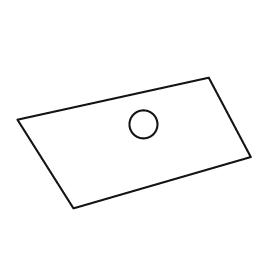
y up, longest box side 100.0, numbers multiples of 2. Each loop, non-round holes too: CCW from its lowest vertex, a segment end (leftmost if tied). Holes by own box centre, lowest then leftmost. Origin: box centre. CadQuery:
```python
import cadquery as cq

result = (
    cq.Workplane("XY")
    .moveTo(-26.0, -28.0)
    .lineTo(50.0, -6.0)
    .lineTo(32.0, 28.0)
    .lineTo(-50.0, 10.0)
    .close()
    .moveTo(4.0, 8.0)
    .circle(6.0)
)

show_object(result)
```